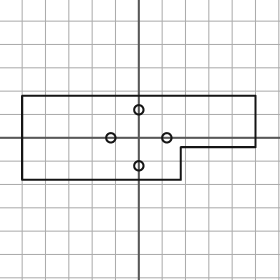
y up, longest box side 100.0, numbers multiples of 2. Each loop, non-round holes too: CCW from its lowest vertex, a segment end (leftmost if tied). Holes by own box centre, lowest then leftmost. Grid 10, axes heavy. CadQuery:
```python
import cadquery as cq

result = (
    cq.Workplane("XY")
    .moveTo(-50.0, -18.0)
    .lineTo(18.0, -18.0)
    .lineTo(18.0, -4.0)
    .lineTo(50.0, -4.0)
    .lineTo(50.0, 18.0)
    .lineTo(-50.0, 18.0)
    .close()
    .moveTo(0.0, -12.0)
    .circle(2.0)
    .moveTo(-12.0, 0.0)
    .circle(2.0)
    .moveTo(12.0, 0.0)
    .circle(2.0)
    .moveTo(0.0, 12.0)
    .circle(2.0)
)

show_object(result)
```